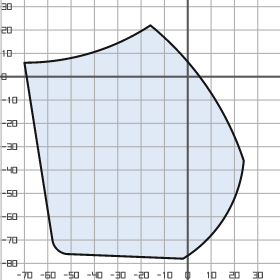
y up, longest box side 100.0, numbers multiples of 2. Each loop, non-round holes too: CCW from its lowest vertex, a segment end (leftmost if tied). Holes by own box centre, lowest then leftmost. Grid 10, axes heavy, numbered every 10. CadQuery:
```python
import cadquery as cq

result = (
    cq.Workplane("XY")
    .moveTo(-2.0, -78.0)
    .threePointArc((16.0, -60.0), (24.0, -36.0))
    .threePointArc((8.0, -4.0), (-16.0, 22.0))
    .threePointArc((-42.0, 10.0), (-70.0, 6.0))
    .lineTo(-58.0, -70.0)
    .threePointArc((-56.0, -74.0), (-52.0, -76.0))
    .close()
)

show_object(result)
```